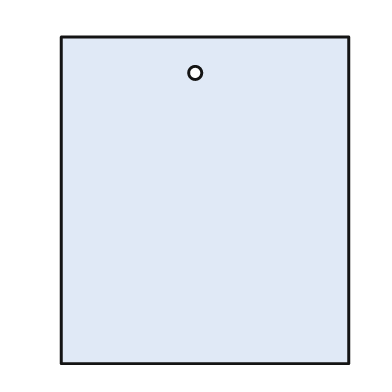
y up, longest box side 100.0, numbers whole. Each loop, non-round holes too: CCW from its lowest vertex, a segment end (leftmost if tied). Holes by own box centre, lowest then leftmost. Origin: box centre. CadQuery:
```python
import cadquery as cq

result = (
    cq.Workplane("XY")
    .moveTo(-44.0, -50.0)
    .lineTo(44.0, -50.0)
    .lineTo(44.0, 50.0)
    .lineTo(-44.0, 50.0)
    .close()
    .moveTo(-3.0, 39.0)
    .circle(2.0)
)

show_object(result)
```